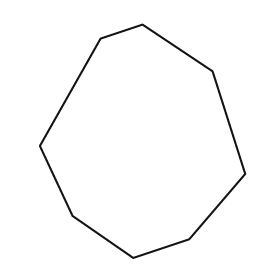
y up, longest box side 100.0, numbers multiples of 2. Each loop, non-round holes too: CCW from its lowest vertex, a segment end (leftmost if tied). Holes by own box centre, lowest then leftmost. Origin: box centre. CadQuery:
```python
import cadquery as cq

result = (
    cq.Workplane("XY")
    .moveTo(-4.0, -50.0)
    .lineTo(20.0, -42.0)
    .lineTo(44.0, -14.0)
    .lineTo(30.0, 30.0)
    .lineTo(0.0, 50.0)
    .lineTo(-18.0, 44.0)
    .lineTo(-44.0, -2.0)
    .lineTo(-30.0, -32.0)
    .close()
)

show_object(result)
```